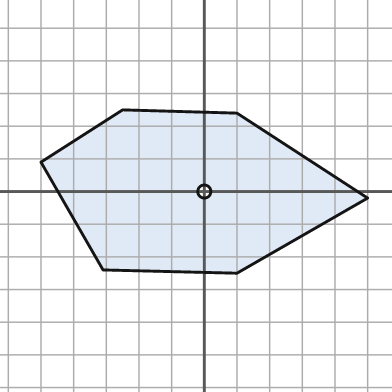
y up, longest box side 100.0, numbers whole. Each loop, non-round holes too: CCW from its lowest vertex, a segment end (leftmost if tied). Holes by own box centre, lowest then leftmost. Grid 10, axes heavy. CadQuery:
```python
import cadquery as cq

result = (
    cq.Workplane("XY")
    .moveTo(10.0, -25.0)
    .lineTo(50.0, -2.0)
    .lineTo(10.0, 24.0)
    .lineTo(-25.0, 25.0)
    .lineTo(-50.0, 9.0)
    .lineTo(-31.0, -24.0)
    .close()
    .moveTo(0.0, 0.0)
    .circle(2.0)
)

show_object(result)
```